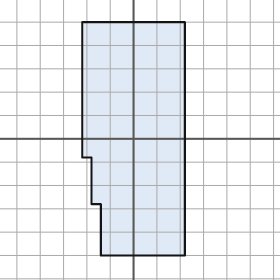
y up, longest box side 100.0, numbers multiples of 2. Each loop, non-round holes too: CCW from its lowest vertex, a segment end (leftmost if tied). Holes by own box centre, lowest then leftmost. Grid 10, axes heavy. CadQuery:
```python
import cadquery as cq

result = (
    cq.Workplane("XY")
    .moveTo(-14.0, -50.0)
    .lineTo(22.0, -50.0)
    .lineTo(22.0, 50.0)
    .lineTo(-22.0, 50.0)
    .lineTo(-22.0, -8.0)
    .lineTo(-18.0, -8.0)
    .lineTo(-18.0, -28.0)
    .lineTo(-14.0, -28.0)
    .close()
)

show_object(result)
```